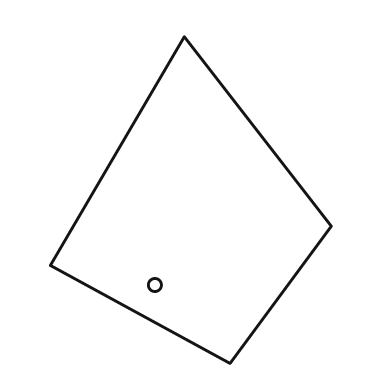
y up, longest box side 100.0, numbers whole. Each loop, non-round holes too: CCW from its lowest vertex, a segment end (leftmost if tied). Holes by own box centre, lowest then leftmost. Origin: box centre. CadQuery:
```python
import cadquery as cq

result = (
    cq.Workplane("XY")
    .moveTo(12.0, -50.0)
    .lineTo(43.0, -8.0)
    .lineTo(-2.0, 50.0)
    .lineTo(-43.0, -20.0)
    .close()
    .moveTo(-11.0, -26.0)
    .circle(2.0)
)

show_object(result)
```